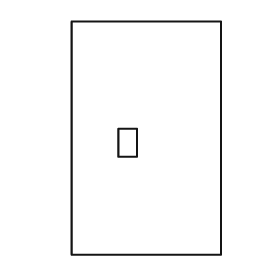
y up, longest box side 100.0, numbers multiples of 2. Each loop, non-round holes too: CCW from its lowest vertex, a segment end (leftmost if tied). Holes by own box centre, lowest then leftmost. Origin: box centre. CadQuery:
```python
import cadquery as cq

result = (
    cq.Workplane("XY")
    .moveTo(-32.0, -50.0)
    .lineTo(32.0, -50.0)
    .lineTo(32.0, 50.0)
    .lineTo(-32.0, 50.0)
    .close()
    .moveTo(-12.0, -8.0)
    .lineTo(-4.0, -8.0)
    .lineTo(-4.0, 4.0)
    .lineTo(-12.0, 4.0)
    .close()
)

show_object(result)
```